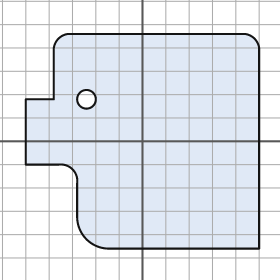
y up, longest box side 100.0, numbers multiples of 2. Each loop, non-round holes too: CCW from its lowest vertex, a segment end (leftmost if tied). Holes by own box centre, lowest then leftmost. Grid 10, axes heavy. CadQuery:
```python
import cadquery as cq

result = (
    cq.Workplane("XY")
    .moveTo(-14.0, -46.0)
    .lineTo(50.0, -46.0)
    .lineTo(50.0, 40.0)
    .threePointArc((48.0, 44.0), (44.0, 46.0))
    .lineTo(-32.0, 46.0)
    .threePointArc((-36.0, 44.0), (-38.0, 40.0))
    .lineTo(-38.0, 18.0)
    .lineTo(-50.0, 18.0)
    .lineTo(-50.0, -10.0)
    .lineTo(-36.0, -10.0)
    .threePointArc((-30.0, -12.0), (-28.0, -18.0))
    .lineTo(-28.0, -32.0)
    .threePointArc((-24.0, -42.0), (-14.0, -46.0))
    .close()
    .moveTo(-24.0, 18.0)
    .circle(4.0)
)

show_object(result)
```